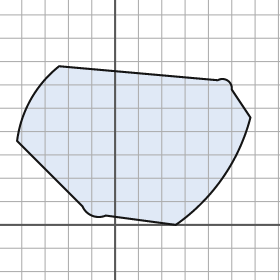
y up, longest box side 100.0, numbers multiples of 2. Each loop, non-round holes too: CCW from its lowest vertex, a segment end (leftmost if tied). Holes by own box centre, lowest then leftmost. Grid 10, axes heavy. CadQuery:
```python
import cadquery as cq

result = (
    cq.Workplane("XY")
    .moveTo(26.0, 0.0)
    .threePointArc((46.0, 20.0), (58.0, 46.0))
    .lineTo(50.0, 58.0)
    .threePointArc((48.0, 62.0), (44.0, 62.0))
    .lineTo(-24.0, 68.0)
    .threePointArc((-36.0, 54.0), (-42.0, 36.0))
    .lineTo(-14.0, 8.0)
    .threePointArc((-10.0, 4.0), (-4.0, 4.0))
    .close()
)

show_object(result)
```